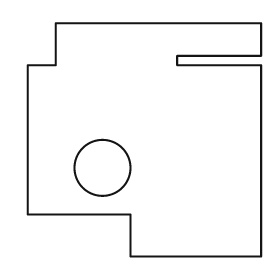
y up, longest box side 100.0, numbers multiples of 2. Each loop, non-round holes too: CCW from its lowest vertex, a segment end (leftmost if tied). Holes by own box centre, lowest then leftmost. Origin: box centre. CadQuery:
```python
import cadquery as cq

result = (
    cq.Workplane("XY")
    .moveTo(-6.0, -50.0)
    .lineTo(50.0, -50.0)
    .lineTo(50.0, 32.0)
    .lineTo(14.0, 32.0)
    .lineTo(14.0, 36.0)
    .lineTo(50.0, 36.0)
    .lineTo(50.0, 50.0)
    .lineTo(-38.0, 50.0)
    .lineTo(-38.0, 32.0)
    .lineTo(-50.0, 32.0)
    .lineTo(-50.0, -32.0)
    .lineTo(-6.0, -32.0)
    .close()
    .moveTo(-18.0, -12.0)
    .circle(12.0)
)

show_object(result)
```